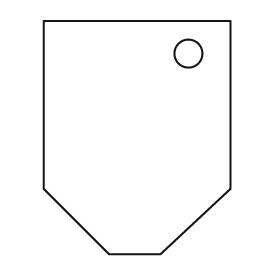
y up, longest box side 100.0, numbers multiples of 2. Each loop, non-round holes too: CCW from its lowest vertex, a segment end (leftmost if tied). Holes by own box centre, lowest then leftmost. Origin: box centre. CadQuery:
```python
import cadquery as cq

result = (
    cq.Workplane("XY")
    .moveTo(-12.0, -50.0)
    .lineTo(10.0, -50.0)
    .lineTo(40.0, -22.0)
    .lineTo(40.0, 50.0)
    .lineTo(-40.0, 50.0)
    .lineTo(-40.0, -22.0)
    .close()
    .moveTo(22.0, 36.0)
    .circle(6.0)
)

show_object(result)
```